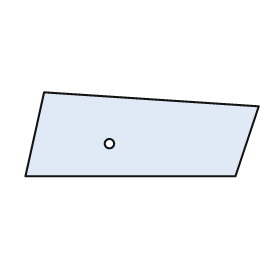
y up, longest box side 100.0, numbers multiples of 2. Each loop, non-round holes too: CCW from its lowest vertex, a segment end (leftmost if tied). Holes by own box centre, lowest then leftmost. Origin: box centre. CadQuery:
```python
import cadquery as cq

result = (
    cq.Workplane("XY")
    .moveTo(-50.0, -18.0)
    .lineTo(40.0, -18.0)
    .lineTo(50.0, 12.0)
    .lineTo(-42.0, 18.0)
    .close()
    .moveTo(-14.0, -4.0)
    .circle(2.0)
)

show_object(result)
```